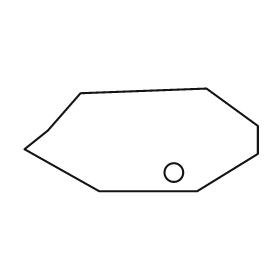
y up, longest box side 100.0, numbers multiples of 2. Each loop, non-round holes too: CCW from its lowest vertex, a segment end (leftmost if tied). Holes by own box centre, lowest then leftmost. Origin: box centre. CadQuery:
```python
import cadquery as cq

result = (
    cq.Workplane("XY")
    .moveTo(-18.0, -22.0)
    .lineTo(24.0, -22.0)
    .lineTo(50.0, -6.0)
    .lineTo(50.0, 6.0)
    .lineTo(28.0, 22.0)
    .lineTo(-26.0, 20.0)
    .lineTo(-40.0, 4.0)
    .lineTo(-50.0, -4.0)
    .close()
    .moveTo(14.0, -14.0)
    .circle(4.0)
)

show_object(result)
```